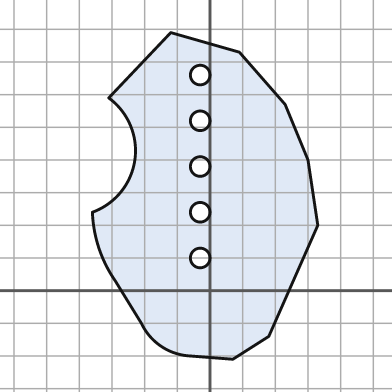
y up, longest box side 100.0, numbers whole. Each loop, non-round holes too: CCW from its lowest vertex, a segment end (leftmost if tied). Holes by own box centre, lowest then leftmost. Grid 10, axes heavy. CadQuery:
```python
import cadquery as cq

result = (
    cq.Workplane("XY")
    .moveTo(7.0, -21.0)
    .lineTo(18.0, -14.0)
    .lineTo(33.0, 20.0)
    .lineTo(30.0, 40.0)
    .lineTo(23.0, 57.0)
    .lineTo(9.0, 73.0)
    .lineTo(-12.0, 79.0)
    .lineTo(-31.0, 59.0)
    .threePointArc((-23.0, 40.0), (-36.0, 24.0))
    .threePointArc((-34.0, 13.0), (-29.0, 3.0))
    .lineTo(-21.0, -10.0)
    .threePointArc((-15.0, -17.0), (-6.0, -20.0))
    .close()
    .moveTo(-3.0, 10.0)
    .circle(3.0)
    .moveTo(-3.0, 24.0)
    .circle(3.0)
    .moveTo(-3.0, 38.0)
    .circle(3.0)
    .moveTo(-3.0, 52.0)
    .circle(3.0)
    .moveTo(-3.0, 66.0)
    .circle(3.0)
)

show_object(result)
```